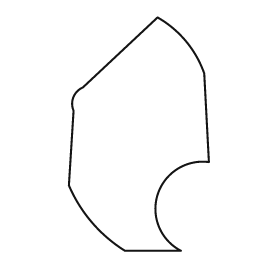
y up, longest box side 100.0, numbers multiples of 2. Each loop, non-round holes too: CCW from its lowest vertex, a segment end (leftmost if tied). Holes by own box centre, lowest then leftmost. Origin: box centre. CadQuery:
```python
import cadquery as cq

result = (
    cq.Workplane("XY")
    .moveTo(-6.0, -50.0)
    .lineTo(18.0, -50.0)
    .threePointArc((8.0, -26.0), (30.0, -12.0))
    .lineTo(28.0, 26.0)
    .threePointArc((20.0, 40.0), (8.0, 50.0))
    .lineTo(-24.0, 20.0)
    .threePointArc((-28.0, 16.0), (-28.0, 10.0))
    .lineTo(-30.0, -22.0)
    .threePointArc((-20.0, -38.0), (-6.0, -50.0))
    .close()
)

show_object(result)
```